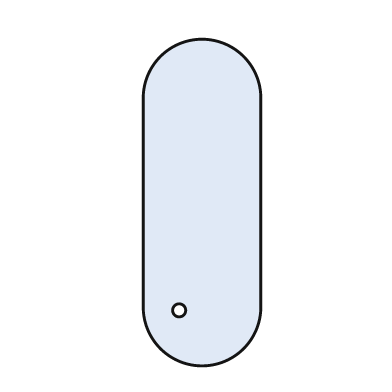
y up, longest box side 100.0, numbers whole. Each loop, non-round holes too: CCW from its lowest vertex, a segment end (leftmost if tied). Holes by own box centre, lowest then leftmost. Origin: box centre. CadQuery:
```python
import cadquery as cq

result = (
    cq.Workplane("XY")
    .moveTo(-18.0, -32.0)
    .threePointArc((0.0, -50.0), (18.0, -32.0))
    .lineTo(18.0, 32.0)
    .threePointArc((0.0, 50.0), (-18.0, 32.0))
    .close()
    .moveTo(-7.0, -33.0)
    .circle(2.0)
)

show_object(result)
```